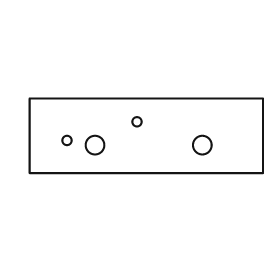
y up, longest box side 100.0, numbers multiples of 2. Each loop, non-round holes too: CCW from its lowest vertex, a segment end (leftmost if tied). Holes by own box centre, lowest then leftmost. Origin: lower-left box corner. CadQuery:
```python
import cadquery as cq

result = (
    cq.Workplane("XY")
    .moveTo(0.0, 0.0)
    .lineTo(100.0, 0.0)
    .lineTo(100.0, 32.0)
    .lineTo(0.0, 32.0)
    .close()
    .moveTo(28.0, 12.0)
    .circle(4.0)
    .moveTo(74.0, 12.0)
    .circle(4.0)
    .moveTo(16.0, 14.0)
    .circle(2.0)
    .moveTo(46.0, 22.0)
    .circle(2.0)
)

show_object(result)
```